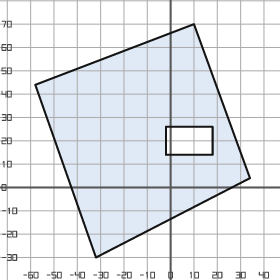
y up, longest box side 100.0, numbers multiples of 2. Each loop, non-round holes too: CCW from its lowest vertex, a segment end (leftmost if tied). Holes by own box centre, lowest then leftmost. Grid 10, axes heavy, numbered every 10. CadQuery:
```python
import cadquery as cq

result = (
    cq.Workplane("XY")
    .moveTo(-32.0, -30.0)
    .lineTo(34.0, 4.0)
    .lineTo(10.0, 70.0)
    .lineTo(-58.0, 44.0)
    .close()
    .moveTo(-2.0, 14.0)
    .lineTo(18.0, 14.0)
    .lineTo(18.0, 26.0)
    .lineTo(-2.0, 26.0)
    .close()
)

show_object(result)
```